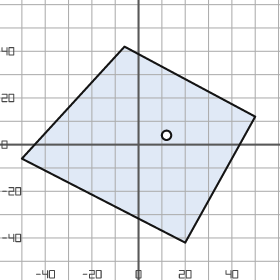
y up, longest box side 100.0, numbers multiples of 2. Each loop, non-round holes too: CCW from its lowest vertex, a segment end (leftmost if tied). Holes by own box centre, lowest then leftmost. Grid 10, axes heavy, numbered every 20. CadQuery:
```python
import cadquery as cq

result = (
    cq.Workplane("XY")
    .moveTo(20.0, -42.0)
    .lineTo(50.0, 12.0)
    .lineTo(-6.0, 42.0)
    .lineTo(-50.0, -6.0)
    .close()
    .moveTo(12.0, 4.0)
    .circle(2.0)
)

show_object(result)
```